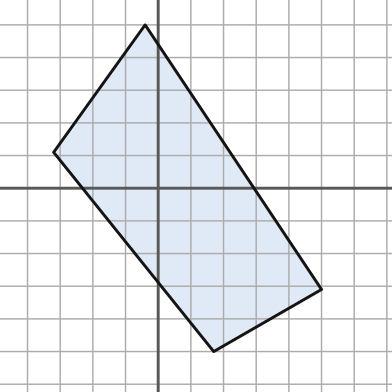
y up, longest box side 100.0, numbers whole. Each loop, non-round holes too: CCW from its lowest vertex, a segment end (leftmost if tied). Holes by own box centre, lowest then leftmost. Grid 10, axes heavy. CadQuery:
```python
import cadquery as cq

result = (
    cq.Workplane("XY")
    .moveTo(17.0, -50.0)
    .lineTo(50.0, -31.0)
    .lineTo(-4.0, 50.0)
    .lineTo(-32.0, 11.0)
    .close()
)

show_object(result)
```